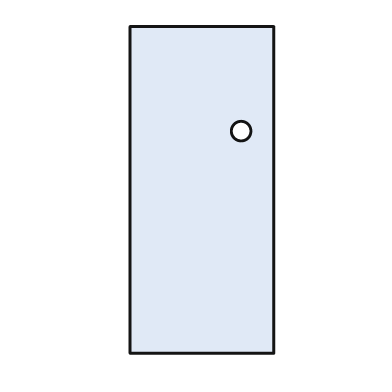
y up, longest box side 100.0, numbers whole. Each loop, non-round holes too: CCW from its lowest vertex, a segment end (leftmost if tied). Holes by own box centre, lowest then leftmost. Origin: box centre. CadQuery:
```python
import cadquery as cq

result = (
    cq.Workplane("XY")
    .moveTo(-22.0, -50.0)
    .lineTo(22.0, -50.0)
    .lineTo(22.0, 50.0)
    .lineTo(-22.0, 50.0)
    .close()
    .moveTo(12.0, 18.0)
    .circle(3.0)
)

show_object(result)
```